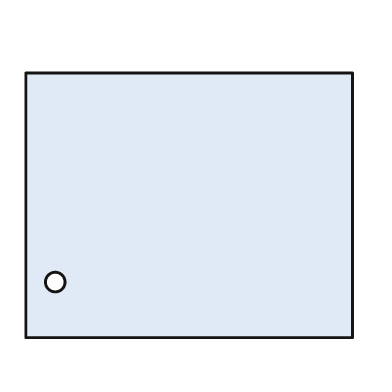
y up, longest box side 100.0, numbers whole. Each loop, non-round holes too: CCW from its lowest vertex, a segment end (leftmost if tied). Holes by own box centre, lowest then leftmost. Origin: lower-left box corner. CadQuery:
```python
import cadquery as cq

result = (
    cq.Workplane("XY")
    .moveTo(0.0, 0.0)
    .lineTo(100.0, 0.0)
    .lineTo(100.0, 81.0)
    .lineTo(0.0, 81.0)
    .close()
    .moveTo(9.0, 17.0)
    .circle(3.0)
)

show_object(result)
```